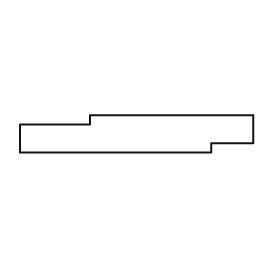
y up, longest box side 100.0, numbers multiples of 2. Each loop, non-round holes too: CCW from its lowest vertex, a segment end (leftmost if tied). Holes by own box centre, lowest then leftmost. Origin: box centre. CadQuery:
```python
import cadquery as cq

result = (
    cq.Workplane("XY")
    .moveTo(-50.0, -8.0)
    .lineTo(32.0, -8.0)
    .lineTo(32.0, -4.0)
    .lineTo(50.0, -4.0)
    .lineTo(50.0, 8.0)
    .lineTo(-20.0, 8.0)
    .lineTo(-20.0, 4.0)
    .lineTo(-50.0, 4.0)
    .close()
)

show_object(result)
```